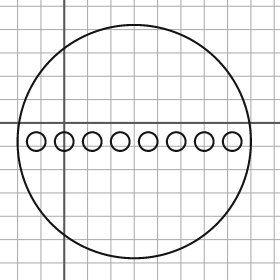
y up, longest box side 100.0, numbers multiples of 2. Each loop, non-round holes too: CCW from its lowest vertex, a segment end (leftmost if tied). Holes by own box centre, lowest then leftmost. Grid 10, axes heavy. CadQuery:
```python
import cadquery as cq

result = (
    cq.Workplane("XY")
    .moveTo(30.0, -8.0)
    .circle(50.0)
    .moveTo(-12.0, -8.0)
    .circle(4.0)
    .moveTo(0.0, -8.0)
    .circle(4.0)
    .moveTo(12.0, -8.0)
    .circle(4.0)
    .moveTo(24.0, -8.0)
    .circle(4.0)
    .moveTo(36.0, -8.0)
    .circle(4.0)
    .moveTo(48.0, -8.0)
    .circle(4.0)
    .moveTo(60.0, -8.0)
    .circle(4.0)
    .moveTo(72.0, -8.0)
    .circle(4.0)
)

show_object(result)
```